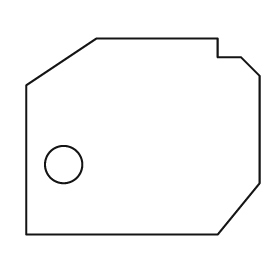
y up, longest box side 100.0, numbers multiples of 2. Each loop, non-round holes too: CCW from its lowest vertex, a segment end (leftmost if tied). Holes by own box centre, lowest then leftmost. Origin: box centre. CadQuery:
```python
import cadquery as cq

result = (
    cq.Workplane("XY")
    .moveTo(-50.0, -42.0)
    .lineTo(32.0, -42.0)
    .lineTo(50.0, -20.0)
    .lineTo(50.0, 26.0)
    .lineTo(42.0, 34.0)
    .lineTo(32.0, 34.0)
    .lineTo(32.0, 42.0)
    .lineTo(-20.0, 42.0)
    .lineTo(-50.0, 22.0)
    .close()
    .moveTo(-34.0, -12.0)
    .circle(8.0)
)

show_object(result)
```